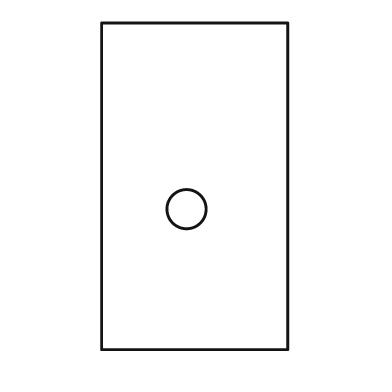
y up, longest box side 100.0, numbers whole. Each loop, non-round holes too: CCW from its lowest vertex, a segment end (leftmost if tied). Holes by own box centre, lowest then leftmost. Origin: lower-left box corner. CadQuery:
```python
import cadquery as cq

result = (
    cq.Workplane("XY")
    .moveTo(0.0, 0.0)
    .lineTo(57.0, 0.0)
    .lineTo(57.0, 100.0)
    .lineTo(0.0, 100.0)
    .close()
    .moveTo(26.0, 43.0)
    .circle(6.0)
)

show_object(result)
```